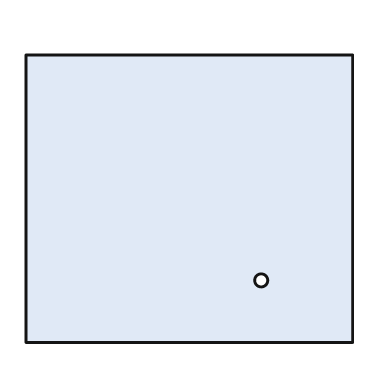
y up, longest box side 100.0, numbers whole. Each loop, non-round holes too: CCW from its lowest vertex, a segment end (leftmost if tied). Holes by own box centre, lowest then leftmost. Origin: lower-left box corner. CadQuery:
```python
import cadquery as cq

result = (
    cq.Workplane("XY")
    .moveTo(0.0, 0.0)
    .lineTo(100.0, 0.0)
    .lineTo(100.0, 88.0)
    .lineTo(0.0, 88.0)
    .close()
    .moveTo(72.0, 19.0)
    .circle(2.0)
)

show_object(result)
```